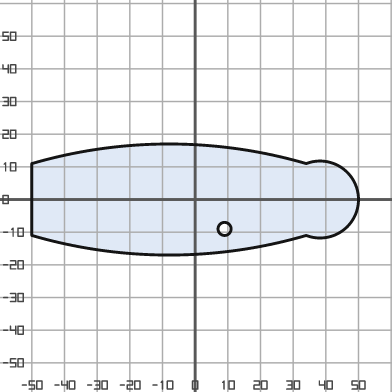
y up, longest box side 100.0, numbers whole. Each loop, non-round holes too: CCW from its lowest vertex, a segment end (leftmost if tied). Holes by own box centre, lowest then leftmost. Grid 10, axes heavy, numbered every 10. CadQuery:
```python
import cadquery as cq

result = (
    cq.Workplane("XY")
    .moveTo(-50.0, -11.0)
    .threePointArc((-8.0, -17.0), (34.0, -11.0))
    .threePointArc((50.0, 0.0), (34.0, 11.0))
    .threePointArc((-8.0, 17.0), (-50.0, 11.0))
    .close()
    .moveTo(9.0, -9.0)
    .circle(2.0)
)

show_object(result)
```